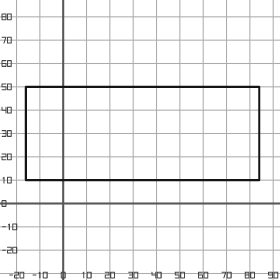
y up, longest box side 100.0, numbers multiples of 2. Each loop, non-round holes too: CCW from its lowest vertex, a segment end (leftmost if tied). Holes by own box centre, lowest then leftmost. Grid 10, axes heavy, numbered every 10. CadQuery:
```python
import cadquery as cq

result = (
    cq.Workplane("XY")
    .moveTo(-16.0, 10.0)
    .lineTo(84.0, 10.0)
    .lineTo(84.0, 50.0)
    .lineTo(-16.0, 50.0)
    .close()
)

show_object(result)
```